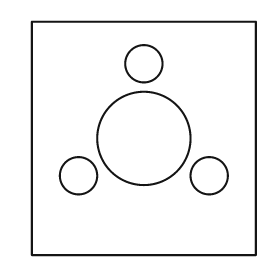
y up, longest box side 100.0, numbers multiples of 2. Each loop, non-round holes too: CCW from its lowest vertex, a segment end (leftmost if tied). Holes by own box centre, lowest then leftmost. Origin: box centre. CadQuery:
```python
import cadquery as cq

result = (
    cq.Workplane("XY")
    .moveTo(-48.0, -50.0)
    .lineTo(48.0, -50.0)
    .lineTo(48.0, 50.0)
    .lineTo(-48.0, 50.0)
    .close()
    .moveTo(-28.0, -16.0)
    .circle(8.0)
    .moveTo(28.0, -16.0)
    .circle(8.0)
    .moveTo(0.0, 0.0)
    .circle(20.0)
    .moveTo(0.0, 32.0)
    .circle(8.0)
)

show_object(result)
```